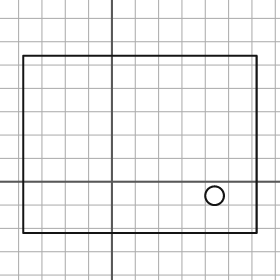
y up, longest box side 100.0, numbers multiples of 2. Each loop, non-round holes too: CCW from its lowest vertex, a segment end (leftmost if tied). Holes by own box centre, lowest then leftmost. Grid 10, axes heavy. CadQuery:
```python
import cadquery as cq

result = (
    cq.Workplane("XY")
    .moveTo(-38.0, -22.0)
    .lineTo(62.0, -22.0)
    .lineTo(62.0, 54.0)
    .lineTo(-38.0, 54.0)
    .close()
    .moveTo(44.0, -6.0)
    .circle(4.0)
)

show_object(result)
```